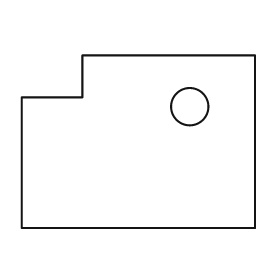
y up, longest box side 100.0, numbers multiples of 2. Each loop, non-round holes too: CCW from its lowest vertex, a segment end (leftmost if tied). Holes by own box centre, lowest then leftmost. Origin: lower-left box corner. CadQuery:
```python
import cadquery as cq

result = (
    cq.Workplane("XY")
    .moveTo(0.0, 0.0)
    .lineTo(100.0, 0.0)
    .lineTo(100.0, 74.0)
    .lineTo(26.0, 74.0)
    .lineTo(26.0, 56.0)
    .lineTo(0.0, 56.0)
    .close()
    .moveTo(72.0, 52.0)
    .circle(8.0)
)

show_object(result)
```